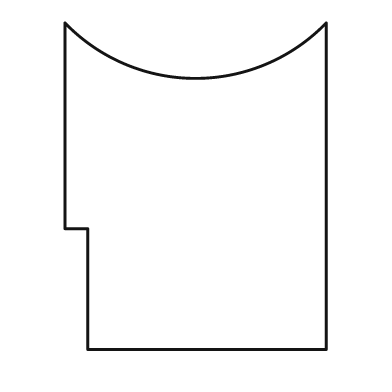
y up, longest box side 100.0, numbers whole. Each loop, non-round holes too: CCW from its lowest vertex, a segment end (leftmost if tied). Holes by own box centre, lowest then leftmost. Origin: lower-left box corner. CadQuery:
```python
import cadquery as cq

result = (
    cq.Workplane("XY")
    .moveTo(7.0, 0.0)
    .lineTo(80.0, 0.0)
    .lineTo(80.0, 100.0)
    .threePointArc((40.0, 83.0), (0.0, 100.0))
    .lineTo(0.0, 37.0)
    .lineTo(7.0, 37.0)
    .close()
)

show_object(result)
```